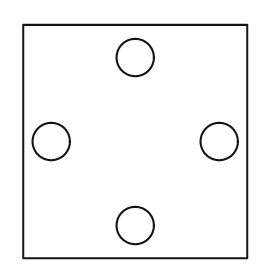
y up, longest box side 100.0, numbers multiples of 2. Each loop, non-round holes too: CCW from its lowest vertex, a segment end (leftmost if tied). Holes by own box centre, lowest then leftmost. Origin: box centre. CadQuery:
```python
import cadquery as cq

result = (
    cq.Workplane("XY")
    .moveTo(-48.0, -50.0)
    .lineTo(48.0, -50.0)
    .lineTo(48.0, 50.0)
    .lineTo(-48.0, 50.0)
    .close()
    .moveTo(0.0, -36.0)
    .circle(8.0)
    .moveTo(-36.0, 0.0)
    .circle(8.0)
    .moveTo(36.0, 0.0)
    .circle(8.0)
    .moveTo(0.0, 36.0)
    .circle(8.0)
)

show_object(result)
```